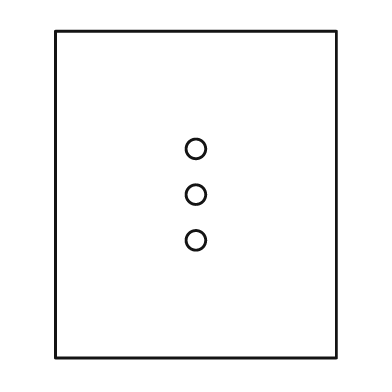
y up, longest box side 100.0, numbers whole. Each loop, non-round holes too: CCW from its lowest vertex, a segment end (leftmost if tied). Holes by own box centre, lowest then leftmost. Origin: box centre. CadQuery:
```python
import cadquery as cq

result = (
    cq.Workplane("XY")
    .moveTo(-43.0, -50.0)
    .lineTo(43.0, -50.0)
    .lineTo(43.0, 50.0)
    .lineTo(-43.0, 50.0)
    .close()
    .moveTo(0.0, -14.0)
    .circle(3.0)
    .moveTo(0.0, 0.0)
    .circle(3.0)
    .moveTo(0.0, 14.0)
    .circle(3.0)
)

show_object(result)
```